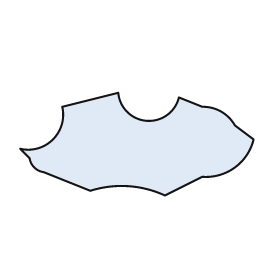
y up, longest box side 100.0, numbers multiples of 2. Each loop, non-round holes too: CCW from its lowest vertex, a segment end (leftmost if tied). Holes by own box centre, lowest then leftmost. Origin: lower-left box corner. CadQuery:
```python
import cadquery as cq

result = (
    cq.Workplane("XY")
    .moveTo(62.0, 0.0)
    .lineTo(78.0, 8.0)
    .threePointArc((92.0, 12.0), (100.0, 24.0))
    .lineTo(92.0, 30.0)
    .threePointArc((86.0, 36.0), (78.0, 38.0))
    .lineTo(68.0, 42.0)
    .threePointArc((54.0, 32.0), (42.0, 44.0))
    .lineTo(18.0, 38.0)
    .threePointArc((14.0, 24.0), (0.0, 20.0))
    .lineTo(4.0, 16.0)
    .threePointArc((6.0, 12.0), (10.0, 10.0))
    .lineTo(30.0, 2.0)
    .threePointArc((46.0, 4.0), (62.0, 0.0))
    .close()
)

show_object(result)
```